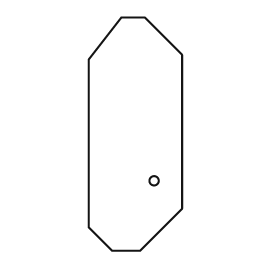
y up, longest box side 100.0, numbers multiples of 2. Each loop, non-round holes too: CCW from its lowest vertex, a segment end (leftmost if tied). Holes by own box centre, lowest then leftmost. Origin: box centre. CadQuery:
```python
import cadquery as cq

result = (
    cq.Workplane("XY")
    .moveTo(-10.0, -50.0)
    .lineTo(2.0, -50.0)
    .lineTo(20.0, -32.0)
    .lineTo(20.0, 34.0)
    .lineTo(4.0, 50.0)
    .lineTo(-6.0, 50.0)
    .lineTo(-20.0, 32.0)
    .lineTo(-20.0, -40.0)
    .close()
    .moveTo(8.0, -20.0)
    .circle(2.0)
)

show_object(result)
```